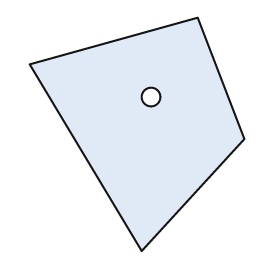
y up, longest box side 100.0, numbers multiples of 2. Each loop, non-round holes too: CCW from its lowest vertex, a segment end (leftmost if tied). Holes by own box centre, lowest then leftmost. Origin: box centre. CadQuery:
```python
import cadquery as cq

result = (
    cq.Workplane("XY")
    .moveTo(2.0, -50.0)
    .lineTo(46.0, -2.0)
    .lineTo(26.0, 50.0)
    .lineTo(-46.0, 30.0)
    .close()
    .moveTo(6.0, 16.0)
    .circle(4.0)
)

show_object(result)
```